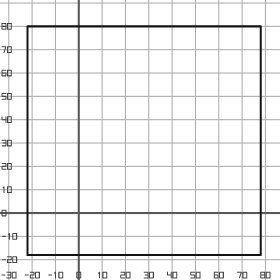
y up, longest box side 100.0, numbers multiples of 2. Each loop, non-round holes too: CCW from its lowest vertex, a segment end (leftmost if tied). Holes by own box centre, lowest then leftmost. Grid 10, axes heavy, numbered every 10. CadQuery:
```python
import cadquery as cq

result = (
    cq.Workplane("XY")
    .moveTo(-22.0, -18.0)
    .lineTo(78.0, -18.0)
    .lineTo(78.0, 80.0)
    .lineTo(-22.0, 80.0)
    .close()
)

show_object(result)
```